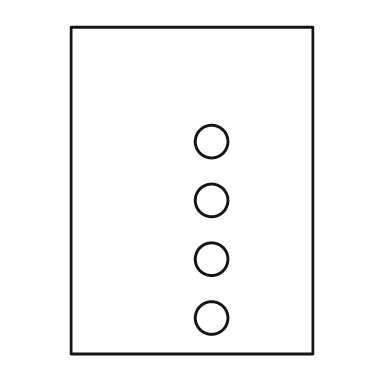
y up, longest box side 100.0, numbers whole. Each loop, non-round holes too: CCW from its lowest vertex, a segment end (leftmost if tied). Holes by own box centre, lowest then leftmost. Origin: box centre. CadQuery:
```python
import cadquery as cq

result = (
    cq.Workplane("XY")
    .moveTo(-37.0, -50.0)
    .lineTo(37.0, -50.0)
    .lineTo(37.0, 50.0)
    .lineTo(-37.0, 50.0)
    .close()
    .moveTo(6.0, -39.0)
    .circle(5.0)
    .moveTo(6.0, -21.0)
    .circle(5.0)
    .moveTo(6.0, -3.0)
    .circle(5.0)
    .moveTo(6.0, 15.0)
    .circle(5.0)
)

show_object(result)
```